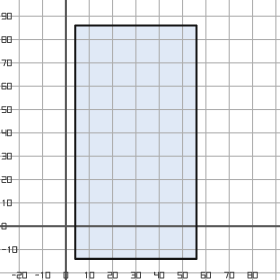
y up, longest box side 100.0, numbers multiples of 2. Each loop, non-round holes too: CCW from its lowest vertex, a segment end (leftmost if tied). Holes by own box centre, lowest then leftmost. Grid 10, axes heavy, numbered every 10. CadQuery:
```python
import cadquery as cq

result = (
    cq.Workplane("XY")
    .moveTo(4.0, -14.0)
    .lineTo(56.0, -14.0)
    .lineTo(56.0, 86.0)
    .lineTo(4.0, 86.0)
    .close()
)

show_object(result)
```